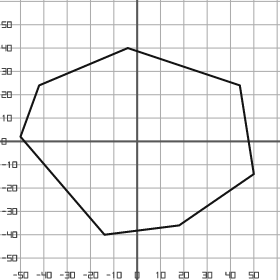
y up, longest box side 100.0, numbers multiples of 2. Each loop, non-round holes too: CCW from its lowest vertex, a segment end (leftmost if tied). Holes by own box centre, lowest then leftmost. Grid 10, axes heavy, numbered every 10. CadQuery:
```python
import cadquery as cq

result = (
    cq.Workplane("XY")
    .moveTo(-14.0, -40.0)
    .lineTo(18.0, -36.0)
    .lineTo(50.0, -14.0)
    .lineTo(44.0, 24.0)
    .lineTo(-4.0, 40.0)
    .lineTo(-42.0, 24.0)
    .lineTo(-50.0, 2.0)
    .close()
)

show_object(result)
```